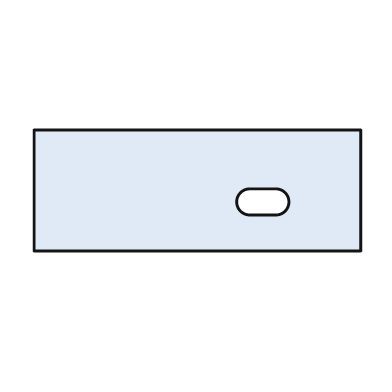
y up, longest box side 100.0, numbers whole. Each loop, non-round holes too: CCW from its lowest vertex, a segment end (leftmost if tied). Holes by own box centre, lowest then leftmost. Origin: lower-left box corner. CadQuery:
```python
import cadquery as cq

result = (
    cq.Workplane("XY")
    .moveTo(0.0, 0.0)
    .lineTo(100.0, 0.0)
    .lineTo(100.0, 37.0)
    .lineTo(0.0, 37.0)
    .close()
    .moveTo(66.0, 11.0)
    .lineTo(74.0, 11.0)
    .threePointArc((78.0, 15.0), (74.0, 19.0))
    .lineTo(66.0, 19.0)
    .threePointArc((62.0, 15.0), (66.0, 11.0))
    .close()
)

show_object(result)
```